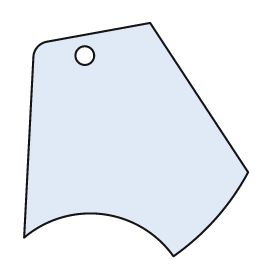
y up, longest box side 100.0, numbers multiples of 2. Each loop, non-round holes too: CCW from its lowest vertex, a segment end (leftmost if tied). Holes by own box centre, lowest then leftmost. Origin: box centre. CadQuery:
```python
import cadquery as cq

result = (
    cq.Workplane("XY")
    .moveTo(16.0, -50.0)
    .threePointArc((34.0, -34.0), (48.0, -14.0))
    .lineTo(6.0, 50.0)
    .lineTo(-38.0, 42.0)
    .threePointArc((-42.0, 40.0), (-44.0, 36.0))
    .lineTo(-48.0, -42.0)
    .threePointArc((-14.0, -32.0), (16.0, -50.0))
    .close()
    .moveTo(-22.0, 36.0)
    .circle(4.0)
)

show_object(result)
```